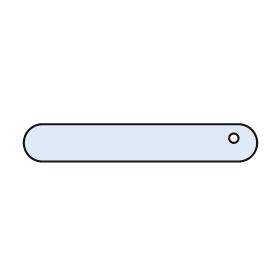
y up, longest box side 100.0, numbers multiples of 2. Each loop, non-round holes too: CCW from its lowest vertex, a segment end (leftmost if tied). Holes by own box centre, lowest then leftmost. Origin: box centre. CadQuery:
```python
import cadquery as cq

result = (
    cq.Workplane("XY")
    .moveTo(-42.0, -8.0)
    .lineTo(42.0, -8.0)
    .threePointArc((50.0, 0.0), (42.0, 8.0))
    .lineTo(-42.0, 8.0)
    .threePointArc((-50.0, 0.0), (-42.0, -8.0))
    .close()
    .moveTo(40.0, 2.0)
    .circle(2.0)
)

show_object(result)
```